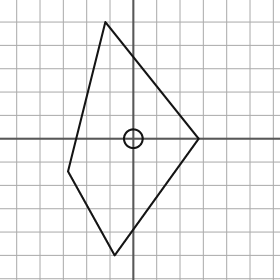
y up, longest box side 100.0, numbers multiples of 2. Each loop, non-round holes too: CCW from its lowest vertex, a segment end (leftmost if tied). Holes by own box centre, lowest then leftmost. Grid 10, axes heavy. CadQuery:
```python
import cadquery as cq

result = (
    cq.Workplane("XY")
    .moveTo(-8.0, -50.0)
    .lineTo(28.0, 0.0)
    .lineTo(-12.0, 50.0)
    .lineTo(-28.0, -14.0)
    .close()
    .moveTo(0.0, 0.0)
    .circle(4.0)
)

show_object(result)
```